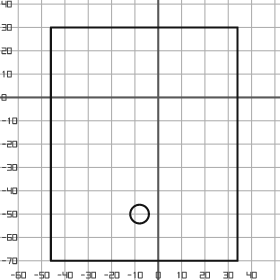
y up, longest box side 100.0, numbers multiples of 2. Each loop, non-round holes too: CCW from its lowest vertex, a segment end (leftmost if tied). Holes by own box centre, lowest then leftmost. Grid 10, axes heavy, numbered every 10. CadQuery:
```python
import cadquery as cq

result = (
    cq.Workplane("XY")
    .moveTo(-46.0, -70.0)
    .lineTo(34.0, -70.0)
    .lineTo(34.0, 30.0)
    .lineTo(-46.0, 30.0)
    .close()
    .moveTo(-8.0, -50.0)
    .circle(4.0)
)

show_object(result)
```